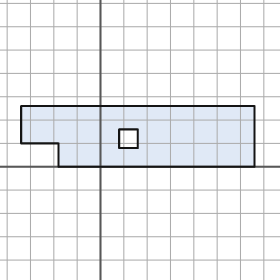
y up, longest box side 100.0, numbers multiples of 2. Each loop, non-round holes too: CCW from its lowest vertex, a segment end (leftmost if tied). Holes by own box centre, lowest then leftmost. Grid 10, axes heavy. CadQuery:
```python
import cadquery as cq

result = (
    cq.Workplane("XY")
    .moveTo(-18.0, 0.0)
    .lineTo(66.0, 0.0)
    .lineTo(66.0, 26.0)
    .lineTo(-34.0, 26.0)
    .lineTo(-34.0, 10.0)
    .lineTo(-18.0, 10.0)
    .close()
    .moveTo(8.0, 8.0)
    .lineTo(16.0, 8.0)
    .lineTo(16.0, 16.0)
    .lineTo(8.0, 16.0)
    .close()
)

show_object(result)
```